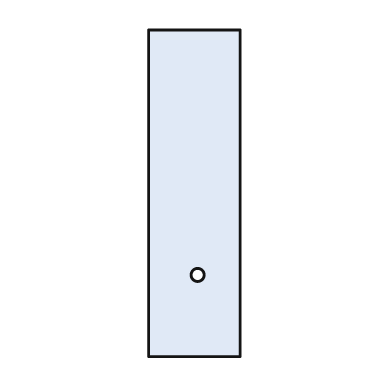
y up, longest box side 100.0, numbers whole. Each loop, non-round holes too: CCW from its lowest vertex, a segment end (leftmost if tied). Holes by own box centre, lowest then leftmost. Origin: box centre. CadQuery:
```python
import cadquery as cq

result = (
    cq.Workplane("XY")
    .moveTo(-14.0, -50.0)
    .lineTo(14.0, -50.0)
    .lineTo(14.0, 50.0)
    .lineTo(-14.0, 50.0)
    .close()
    .moveTo(1.0, -25.0)
    .circle(2.0)
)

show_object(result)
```